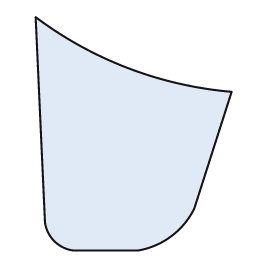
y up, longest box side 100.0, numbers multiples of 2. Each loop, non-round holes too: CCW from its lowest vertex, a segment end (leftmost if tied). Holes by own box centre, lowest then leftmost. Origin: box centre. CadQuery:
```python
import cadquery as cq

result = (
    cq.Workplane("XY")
    .moveTo(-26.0, -50.0)
    .lineTo(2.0, -50.0)
    .threePointArc((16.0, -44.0), (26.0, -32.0))
    .lineTo(42.0, 18.0)
    .threePointArc((-2.0, 28.0), (-42.0, 50.0))
    .lineTo(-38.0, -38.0)
    .threePointArc((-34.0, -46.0), (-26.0, -50.0))
    .close()
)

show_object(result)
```